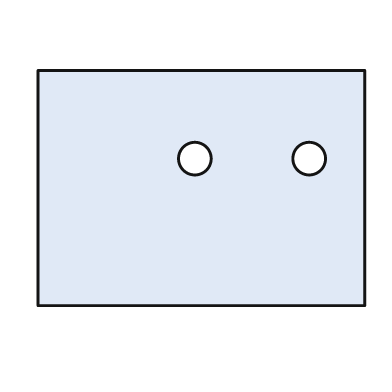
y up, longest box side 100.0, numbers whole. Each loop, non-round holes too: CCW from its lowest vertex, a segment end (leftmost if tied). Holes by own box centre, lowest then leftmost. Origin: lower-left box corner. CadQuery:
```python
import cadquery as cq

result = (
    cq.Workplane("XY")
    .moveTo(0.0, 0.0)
    .lineTo(100.0, 0.0)
    .lineTo(100.0, 72.0)
    .lineTo(0.0, 72.0)
    .close()
    .moveTo(48.0, 45.0)
    .circle(5.0)
    .moveTo(83.0, 45.0)
    .circle(5.0)
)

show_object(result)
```